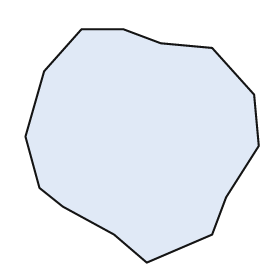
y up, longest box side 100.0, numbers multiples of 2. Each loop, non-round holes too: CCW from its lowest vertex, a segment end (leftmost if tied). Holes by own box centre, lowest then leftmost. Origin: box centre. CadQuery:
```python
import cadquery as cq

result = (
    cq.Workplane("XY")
    .moveTo(2.0, -50.0)
    .lineTo(30.0, -38.0)
    .lineTo(36.0, -22.0)
    .lineTo(50.0, 0.0)
    .lineTo(48.0, 22.0)
    .lineTo(30.0, 42.0)
    .lineTo(8.0, 44.0)
    .lineTo(-8.0, 50.0)
    .lineTo(-26.0, 50.0)
    .lineTo(-42.0, 32.0)
    .lineTo(-50.0, 4.0)
    .lineTo(-44.0, -18.0)
    .lineTo(-34.0, -26.0)
    .lineTo(-12.0, -38.0)
    .close()
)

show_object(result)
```